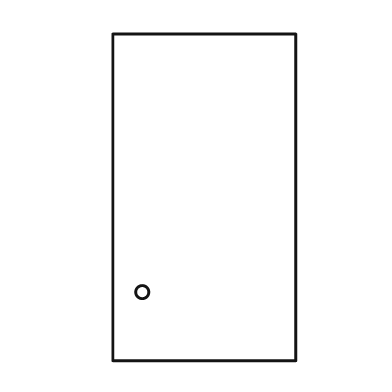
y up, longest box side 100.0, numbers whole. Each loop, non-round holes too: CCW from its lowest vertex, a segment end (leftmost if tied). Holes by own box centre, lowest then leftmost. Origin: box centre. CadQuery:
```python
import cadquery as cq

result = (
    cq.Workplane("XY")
    .moveTo(-28.0, -50.0)
    .lineTo(28.0, -50.0)
    .lineTo(28.0, 50.0)
    .lineTo(-28.0, 50.0)
    .close()
    .moveTo(-19.0, -29.0)
    .circle(2.0)
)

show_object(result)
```